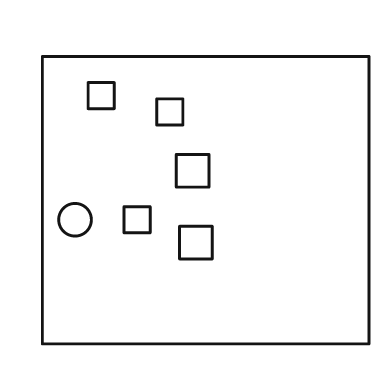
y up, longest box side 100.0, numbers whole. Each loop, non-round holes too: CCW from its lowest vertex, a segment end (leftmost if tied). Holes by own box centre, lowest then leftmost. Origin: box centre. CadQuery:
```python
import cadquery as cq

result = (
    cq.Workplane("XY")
    .moveTo(-50.0, -44.0)
    .lineTo(50.0, -44.0)
    .lineTo(50.0, 44.0)
    .lineTo(-50.0, 44.0)
    .close()
    .moveTo(-8.0, -18.0)
    .lineTo(2.0, -18.0)
    .lineTo(2.0, -8.0)
    .lineTo(-8.0, -8.0)
    .close()
    .moveTo(-40.0, -6.0)
    .circle(5.0)
    .moveTo(-25.0, -10.0)
    .lineTo(-17.0, -10.0)
    .lineTo(-17.0, -2.0)
    .lineTo(-25.0, -2.0)
    .close()
    .moveTo(-9.0, 4.0)
    .lineTo(1.0, 4.0)
    .lineTo(1.0, 14.0)
    .lineTo(-9.0, 14.0)
    .close()
    .moveTo(-15.0, 23.0)
    .lineTo(-7.0, 23.0)
    .lineTo(-7.0, 31.0)
    .lineTo(-15.0, 31.0)
    .close()
    .moveTo(-36.0, 28.0)
    .lineTo(-28.0, 28.0)
    .lineTo(-28.0, 36.0)
    .lineTo(-36.0, 36.0)
    .close()
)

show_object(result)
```